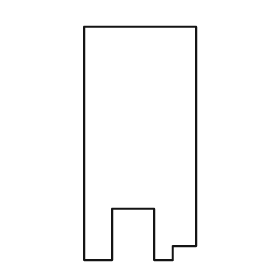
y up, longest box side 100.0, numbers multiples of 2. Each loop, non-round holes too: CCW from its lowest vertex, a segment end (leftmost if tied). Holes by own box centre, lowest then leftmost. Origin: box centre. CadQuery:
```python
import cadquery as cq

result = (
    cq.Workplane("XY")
    .moveTo(-24.0, -50.0)
    .lineTo(-12.0, -50.0)
    .lineTo(-12.0, -28.0)
    .lineTo(6.0, -28.0)
    .lineTo(6.0, -50.0)
    .lineTo(14.0, -50.0)
    .lineTo(14.0, -44.0)
    .lineTo(24.0, -44.0)
    .lineTo(24.0, 50.0)
    .lineTo(-24.0, 50.0)
    .close()
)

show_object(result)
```